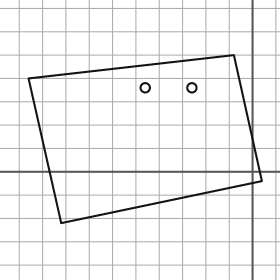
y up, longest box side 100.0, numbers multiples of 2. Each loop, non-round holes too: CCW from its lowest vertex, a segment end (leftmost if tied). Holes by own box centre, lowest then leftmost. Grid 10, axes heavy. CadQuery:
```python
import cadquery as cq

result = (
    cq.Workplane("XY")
    .moveTo(-82.0, -22.0)
    .lineTo(4.0, -4.0)
    .lineTo(-8.0, 50.0)
    .lineTo(-96.0, 40.0)
    .close()
    .moveTo(-46.0, 36.0)
    .circle(2.0)
    .moveTo(-26.0, 36.0)
    .circle(2.0)
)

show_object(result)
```